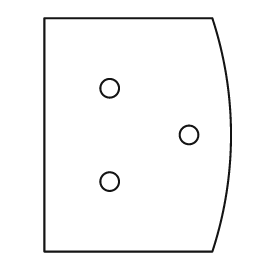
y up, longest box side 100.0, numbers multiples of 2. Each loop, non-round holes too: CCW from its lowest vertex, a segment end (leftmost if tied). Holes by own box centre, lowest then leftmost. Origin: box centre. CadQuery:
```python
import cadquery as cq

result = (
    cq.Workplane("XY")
    .moveTo(-40.0, -50.0)
    .lineTo(32.0, -50.0)
    .threePointArc((40.0, 0.0), (32.0, 50.0))
    .lineTo(-40.0, 50.0)
    .close()
    .moveTo(-12.0, -20.0)
    .circle(4.0)
    .moveTo(22.0, 0.0)
    .circle(4.0)
    .moveTo(-12.0, 20.0)
    .circle(4.0)
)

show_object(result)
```